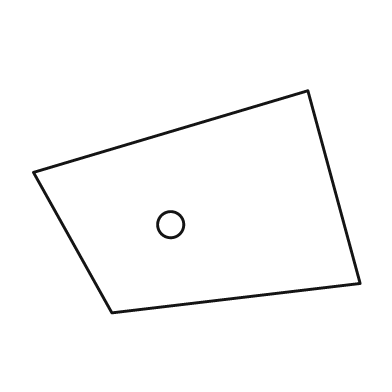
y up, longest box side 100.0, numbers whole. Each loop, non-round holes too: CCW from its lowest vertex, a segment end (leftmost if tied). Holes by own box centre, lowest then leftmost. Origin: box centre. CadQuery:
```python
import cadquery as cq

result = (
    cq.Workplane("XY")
    .moveTo(-26.0, -34.0)
    .lineTo(50.0, -25.0)
    .lineTo(34.0, 34.0)
    .lineTo(-50.0, 9.0)
    .close()
    .moveTo(-8.0, -7.0)
    .circle(4.0)
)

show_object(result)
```